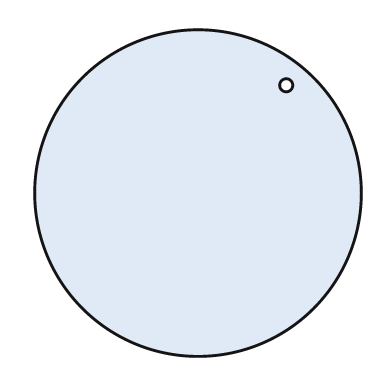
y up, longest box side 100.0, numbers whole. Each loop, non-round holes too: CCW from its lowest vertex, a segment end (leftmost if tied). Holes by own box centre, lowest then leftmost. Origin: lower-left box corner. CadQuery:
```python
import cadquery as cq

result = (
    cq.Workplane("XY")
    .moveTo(50.0, 50.0)
    .circle(50.0)
    .moveTo(77.0, 83.0)
    .circle(2.0)
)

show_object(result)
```